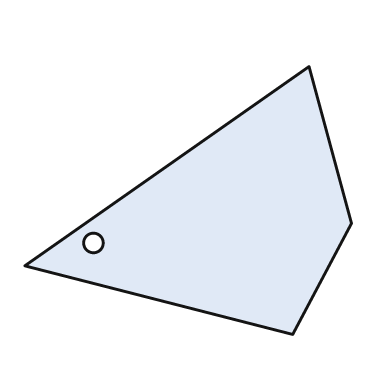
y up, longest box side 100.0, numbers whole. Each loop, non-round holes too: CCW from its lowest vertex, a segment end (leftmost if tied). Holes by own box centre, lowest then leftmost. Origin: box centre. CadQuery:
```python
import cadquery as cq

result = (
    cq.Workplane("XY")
    .moveTo(32.0, -41.0)
    .lineTo(50.0, -7.0)
    .lineTo(37.0, 41.0)
    .lineTo(-50.0, -20.0)
    .close()
    .moveTo(-29.0, -13.0)
    .circle(3.0)
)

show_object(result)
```